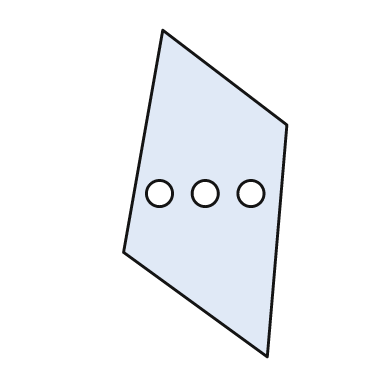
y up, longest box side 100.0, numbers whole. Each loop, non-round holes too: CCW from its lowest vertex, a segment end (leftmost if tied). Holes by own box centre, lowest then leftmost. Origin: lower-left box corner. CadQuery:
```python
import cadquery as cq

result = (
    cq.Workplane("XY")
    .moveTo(44.0, 0.0)
    .lineTo(50.0, 71.0)
    .lineTo(12.0, 100.0)
    .lineTo(0.0, 32.0)
    .close()
    .moveTo(11.0, 50.0)
    .circle(4.0)
    .moveTo(25.0, 50.0)
    .circle(4.0)
    .moveTo(39.0, 50.0)
    .circle(4.0)
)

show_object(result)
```